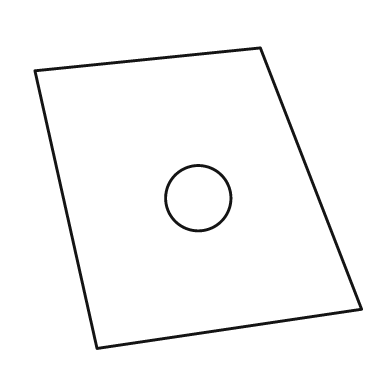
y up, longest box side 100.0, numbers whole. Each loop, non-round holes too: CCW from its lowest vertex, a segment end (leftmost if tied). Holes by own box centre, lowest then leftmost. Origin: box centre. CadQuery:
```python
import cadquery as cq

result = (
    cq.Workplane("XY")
    .moveTo(-31.0, -46.0)
    .lineTo(50.0, -34.0)
    .lineTo(19.0, 46.0)
    .lineTo(-50.0, 39.0)
    .close()
    .moveTo(0.0, 0.0)
    .circle(10.0)
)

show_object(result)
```